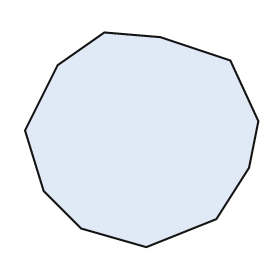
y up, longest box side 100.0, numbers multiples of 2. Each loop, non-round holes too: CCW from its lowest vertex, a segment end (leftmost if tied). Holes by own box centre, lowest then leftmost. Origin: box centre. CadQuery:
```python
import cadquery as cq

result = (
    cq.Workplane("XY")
    .moveTo(2.0, -46.0)
    .lineTo(32.0, -34.0)
    .lineTo(46.0, -12.0)
    .lineTo(50.0, 8.0)
    .lineTo(38.0, 34.0)
    .lineTo(8.0, 44.0)
    .lineTo(-16.0, 46.0)
    .lineTo(-36.0, 32.0)
    .lineTo(-50.0, 4.0)
    .lineTo(-42.0, -22.0)
    .lineTo(-26.0, -38.0)
    .close()
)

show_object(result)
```